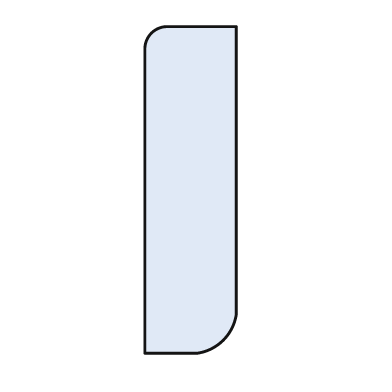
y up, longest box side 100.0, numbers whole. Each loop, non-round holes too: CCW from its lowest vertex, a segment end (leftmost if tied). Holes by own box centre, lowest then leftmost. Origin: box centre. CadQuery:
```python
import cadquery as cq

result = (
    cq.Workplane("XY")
    .moveTo(-14.0, -50.0)
    .lineTo(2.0, -50.0)
    .threePointArc((10.0, -46.0), (14.0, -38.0))
    .lineTo(14.0, 50.0)
    .lineTo(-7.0, 50.0)
    .threePointArc((-12.0, 48.0), (-14.0, 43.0))
    .close()
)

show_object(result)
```